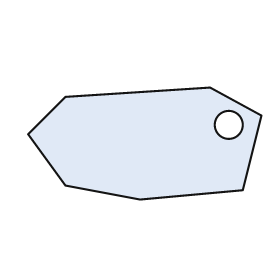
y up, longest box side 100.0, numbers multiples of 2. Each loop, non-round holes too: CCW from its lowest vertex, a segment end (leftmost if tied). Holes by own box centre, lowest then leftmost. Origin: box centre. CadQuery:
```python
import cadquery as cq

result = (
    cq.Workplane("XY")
    .moveTo(-2.0, -24.0)
    .lineTo(42.0, -20.0)
    .lineTo(50.0, 12.0)
    .lineTo(28.0, 24.0)
    .lineTo(-34.0, 20.0)
    .lineTo(-50.0, 4.0)
    .lineTo(-34.0, -18.0)
    .close()
    .moveTo(36.0, 8.0)
    .circle(6.0)
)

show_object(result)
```